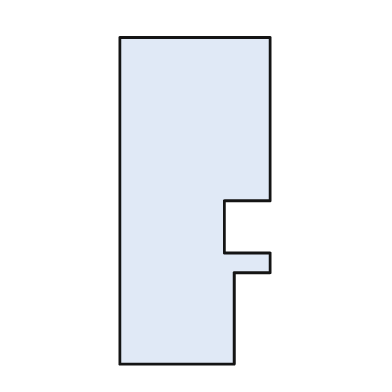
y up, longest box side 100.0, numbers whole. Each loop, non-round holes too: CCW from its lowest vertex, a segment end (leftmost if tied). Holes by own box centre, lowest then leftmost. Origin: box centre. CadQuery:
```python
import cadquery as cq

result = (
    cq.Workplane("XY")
    .moveTo(-23.0, -50.0)
    .lineTo(12.0, -50.0)
    .lineTo(12.0, -22.0)
    .lineTo(23.0, -22.0)
    .lineTo(23.0, -16.0)
    .lineTo(9.0, -16.0)
    .lineTo(9.0, 0.0)
    .lineTo(23.0, 0.0)
    .lineTo(23.0, 50.0)
    .lineTo(-23.0, 50.0)
    .close()
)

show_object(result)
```